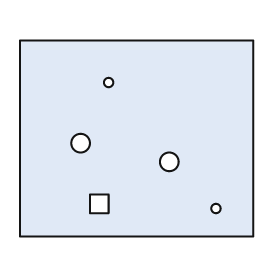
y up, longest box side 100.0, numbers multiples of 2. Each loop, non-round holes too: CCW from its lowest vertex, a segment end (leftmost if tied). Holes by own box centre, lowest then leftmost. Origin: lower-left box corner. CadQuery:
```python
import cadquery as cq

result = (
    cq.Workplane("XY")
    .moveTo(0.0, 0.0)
    .lineTo(100.0, 0.0)
    .lineTo(100.0, 84.0)
    .lineTo(0.0, 84.0)
    .close()
    .moveTo(84.0, 12.0)
    .circle(2.0)
    .moveTo(30.0, 10.0)
    .lineTo(38.0, 10.0)
    .lineTo(38.0, 18.0)
    .lineTo(30.0, 18.0)
    .close()
    .moveTo(64.0, 32.0)
    .circle(4.0)
    .moveTo(26.0, 40.0)
    .circle(4.0)
    .moveTo(38.0, 66.0)
    .circle(2.0)
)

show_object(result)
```